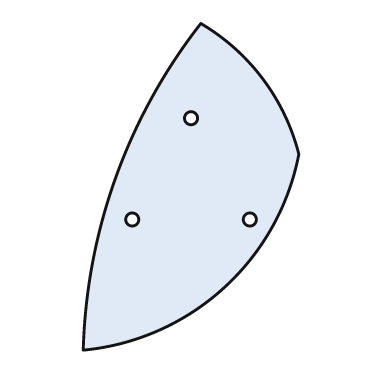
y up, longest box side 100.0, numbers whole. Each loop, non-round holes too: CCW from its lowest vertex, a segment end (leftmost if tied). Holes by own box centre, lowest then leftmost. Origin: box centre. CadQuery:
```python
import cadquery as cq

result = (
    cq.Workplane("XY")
    .moveTo(-33.0, -50.0)
    .threePointArc((10.0, -31.0), (33.0, 10.0))
    .threePointArc((22.0, 33.0), (3.0, 50.0))
    .threePointArc((-23.0, 3.0), (-33.0, -50.0))
    .close()
    .moveTo(-18.0, -10.0)
    .circle(2.0)
    .moveTo(18.0, -10.0)
    .circle(2.0)
    .moveTo(0.0, 21.0)
    .circle(2.0)
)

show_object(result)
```